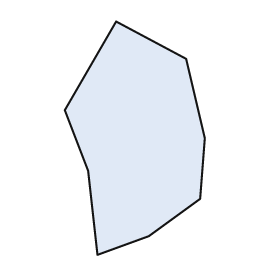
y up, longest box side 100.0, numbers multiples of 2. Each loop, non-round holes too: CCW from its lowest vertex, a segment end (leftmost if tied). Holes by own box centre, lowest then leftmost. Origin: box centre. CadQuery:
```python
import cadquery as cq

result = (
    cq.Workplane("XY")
    .moveTo(-16.0, -50.0)
    .lineTo(6.0, -42.0)
    .lineTo(28.0, -26.0)
    .lineTo(30.0, 0.0)
    .lineTo(22.0, 34.0)
    .lineTo(-8.0, 50.0)
    .lineTo(-30.0, 12.0)
    .lineTo(-20.0, -14.0)
    .close()
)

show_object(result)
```